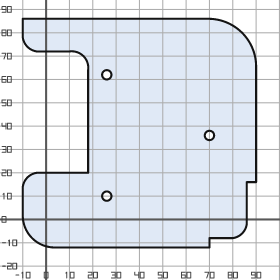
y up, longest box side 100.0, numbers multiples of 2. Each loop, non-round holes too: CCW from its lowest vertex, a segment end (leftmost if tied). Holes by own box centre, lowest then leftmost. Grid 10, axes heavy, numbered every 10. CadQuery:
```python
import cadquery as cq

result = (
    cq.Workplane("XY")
    .moveTo(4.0, -12.0)
    .lineTo(70.0, -12.0)
    .lineTo(70.0, -8.0)
    .lineTo(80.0, -8.0)
    .threePointArc((84.0, -6.0), (86.0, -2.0))
    .lineTo(86.0, 16.0)
    .lineTo(90.0, 16.0)
    .lineTo(90.0, 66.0)
    .threePointArc((84.0, 80.0), (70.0, 86.0))
    .lineTo(-10.0, 86.0)
    .lineTo(-10.0, 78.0)
    .threePointArc((-8.0, 74.0), (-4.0, 72.0))
    .lineTo(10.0, 72.0)
    .threePointArc((16.0, 70.0), (18.0, 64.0))
    .lineTo(18.0, 20.0)
    .lineTo(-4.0, 20.0)
    .threePointArc((-8.0, 18.0), (-10.0, 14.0))
    .lineTo(-10.0, 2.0)
    .threePointArc((-6.0, -8.0), (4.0, -12.0))
    .close()
    .moveTo(26.0, 10.0)
    .circle(2.0)
    .moveTo(70.0, 36.0)
    .circle(2.0)
    .moveTo(26.0, 62.0)
    .circle(2.0)
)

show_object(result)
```